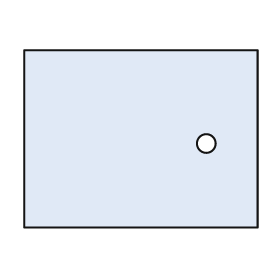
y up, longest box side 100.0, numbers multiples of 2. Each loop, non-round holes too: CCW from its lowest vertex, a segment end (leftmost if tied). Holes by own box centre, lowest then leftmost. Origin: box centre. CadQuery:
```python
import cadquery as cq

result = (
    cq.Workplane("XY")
    .moveTo(-50.0, -38.0)
    .lineTo(50.0, -38.0)
    .lineTo(50.0, 38.0)
    .lineTo(-50.0, 38.0)
    .close()
    .moveTo(28.0, -2.0)
    .circle(4.0)
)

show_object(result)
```